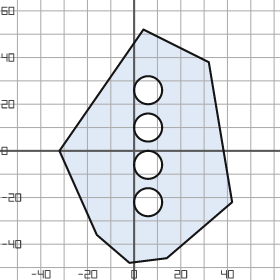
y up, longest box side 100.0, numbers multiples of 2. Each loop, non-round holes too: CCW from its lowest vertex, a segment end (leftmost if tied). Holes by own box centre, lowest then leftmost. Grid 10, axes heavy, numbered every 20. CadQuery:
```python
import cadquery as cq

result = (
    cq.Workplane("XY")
    .moveTo(-2.0, -48.0)
    .lineTo(14.0, -46.0)
    .lineTo(42.0, -22.0)
    .lineTo(32.0, 38.0)
    .lineTo(4.0, 52.0)
    .lineTo(-32.0, 0.0)
    .lineTo(-16.0, -36.0)
    .close()
    .moveTo(6.0, -22.0)
    .circle(6.0)
    .moveTo(6.0, -6.0)
    .circle(6.0)
    .moveTo(6.0, 10.0)
    .circle(6.0)
    .moveTo(6.0, 26.0)
    .circle(6.0)
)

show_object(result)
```